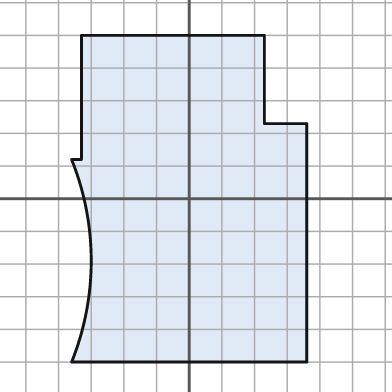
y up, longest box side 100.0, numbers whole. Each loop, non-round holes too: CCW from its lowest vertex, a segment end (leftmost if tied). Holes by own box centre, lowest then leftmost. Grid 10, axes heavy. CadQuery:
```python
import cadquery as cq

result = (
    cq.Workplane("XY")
    .moveTo(-36.0, -50.0)
    .lineTo(36.0, -50.0)
    .lineTo(36.0, 23.0)
    .lineTo(23.0, 23.0)
    .lineTo(23.0, 50.0)
    .lineTo(-33.0, 50.0)
    .lineTo(-33.0, 12.0)
    .lineTo(-36.0, 12.0)
    .threePointArc((-30.0, -19.0), (-36.0, -50.0))
    .close()
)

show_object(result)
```